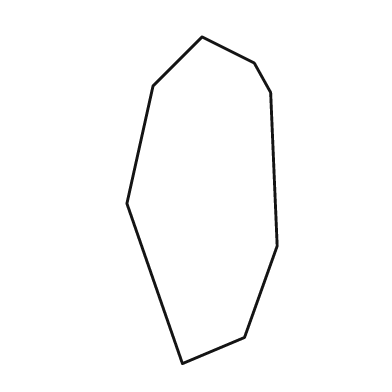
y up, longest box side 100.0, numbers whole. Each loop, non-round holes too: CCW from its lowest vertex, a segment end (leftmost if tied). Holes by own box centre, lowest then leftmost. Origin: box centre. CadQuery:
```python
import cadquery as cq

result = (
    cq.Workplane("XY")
    .moveTo(-6.0, -50.0)
    .lineTo(13.0, -42.0)
    .lineTo(23.0, -14.0)
    .lineTo(21.0, 33.0)
    .lineTo(16.0, 42.0)
    .lineTo(0.0, 50.0)
    .lineTo(-15.0, 35.0)
    .lineTo(-23.0, -1.0)
    .close()
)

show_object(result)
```